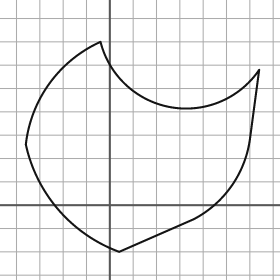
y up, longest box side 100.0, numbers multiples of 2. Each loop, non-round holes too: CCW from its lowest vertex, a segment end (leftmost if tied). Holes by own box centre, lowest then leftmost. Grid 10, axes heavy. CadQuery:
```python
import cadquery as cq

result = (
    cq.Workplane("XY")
    .moveTo(4.0, -20.0)
    .lineTo(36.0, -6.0)
    .threePointArc((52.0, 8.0), (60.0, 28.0))
    .lineTo(64.0, 58.0)
    .threePointArc((26.0, 42.0), (-4.0, 70.0))
    .threePointArc((-26.0, 52.0), (-36.0, 26.0))
    .threePointArc((-22.0, -2.0), (4.0, -20.0))
    .close()
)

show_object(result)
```